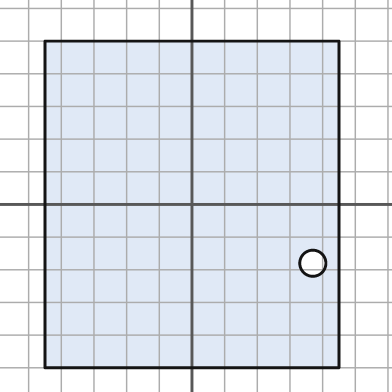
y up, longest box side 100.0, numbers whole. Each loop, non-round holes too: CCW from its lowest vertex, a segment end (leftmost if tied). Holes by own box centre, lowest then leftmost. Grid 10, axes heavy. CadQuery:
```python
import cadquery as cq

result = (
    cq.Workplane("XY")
    .moveTo(-45.0, -50.0)
    .lineTo(45.0, -50.0)
    .lineTo(45.0, 50.0)
    .lineTo(-45.0, 50.0)
    .close()
    .moveTo(37.0, -18.0)
    .circle(4.0)
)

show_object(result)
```